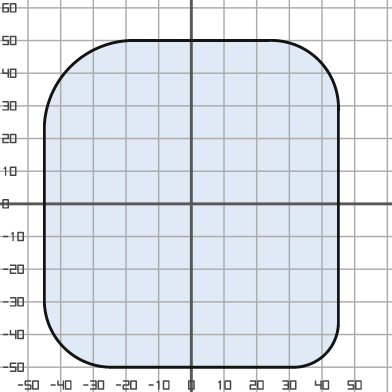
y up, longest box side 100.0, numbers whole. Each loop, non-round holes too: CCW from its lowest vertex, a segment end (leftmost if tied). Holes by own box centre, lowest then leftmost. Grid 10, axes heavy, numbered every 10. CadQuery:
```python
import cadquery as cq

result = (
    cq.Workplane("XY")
    .moveTo(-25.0, -50.0)
    .lineTo(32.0, -50.0)
    .threePointArc((41.0, -46.0), (45.0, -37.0))
    .lineTo(45.0, 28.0)
    .threePointArc((39.0, 44.0), (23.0, 50.0))
    .lineTo(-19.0, 50.0)
    .threePointArc((-37.0, 42.0), (-45.0, 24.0))
    .lineTo(-45.0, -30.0)
    .threePointArc((-39.0, -44.0), (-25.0, -50.0))
    .close()
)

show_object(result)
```